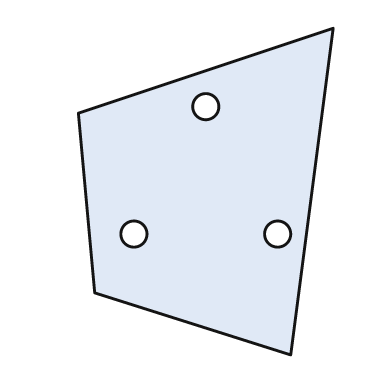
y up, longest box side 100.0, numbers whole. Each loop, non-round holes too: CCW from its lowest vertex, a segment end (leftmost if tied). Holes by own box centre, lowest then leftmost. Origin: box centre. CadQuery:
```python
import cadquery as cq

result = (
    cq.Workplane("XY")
    .moveTo(26.0, -50.0)
    .lineTo(39.0, 50.0)
    .lineTo(-39.0, 24.0)
    .lineTo(-34.0, -31.0)
    .close()
    .moveTo(-22.0, -13.0)
    .circle(4.0)
    .moveTo(22.0, -13.0)
    .circle(4.0)
    .moveTo(0.0, 26.0)
    .circle(4.0)
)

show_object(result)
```